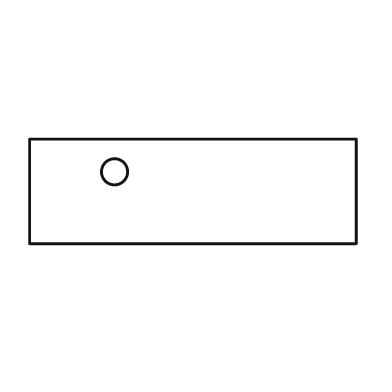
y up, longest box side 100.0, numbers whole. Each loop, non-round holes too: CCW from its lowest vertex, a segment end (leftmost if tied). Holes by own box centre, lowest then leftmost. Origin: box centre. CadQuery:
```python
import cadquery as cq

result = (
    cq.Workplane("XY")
    .moveTo(-50.0, -16.0)
    .lineTo(50.0, -16.0)
    .lineTo(50.0, 16.0)
    .lineTo(-50.0, 16.0)
    .close()
    .moveTo(-24.0, 6.0)
    .circle(4.0)
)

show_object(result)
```